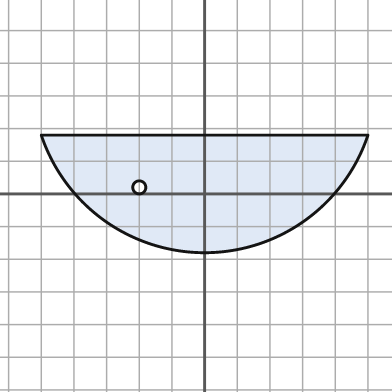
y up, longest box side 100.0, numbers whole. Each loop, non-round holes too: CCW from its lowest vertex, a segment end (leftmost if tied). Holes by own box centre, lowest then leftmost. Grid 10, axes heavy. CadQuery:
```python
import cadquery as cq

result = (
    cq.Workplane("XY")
    .moveTo(-50.0, 18.0)
    .threePointArc((0.0, -18.0), (50.0, 18.0))
    .close()
    .moveTo(-20.0, 2.0)
    .circle(2.0)
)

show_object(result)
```